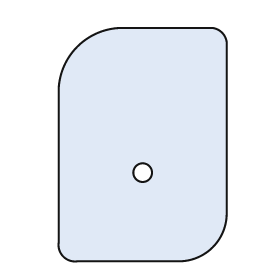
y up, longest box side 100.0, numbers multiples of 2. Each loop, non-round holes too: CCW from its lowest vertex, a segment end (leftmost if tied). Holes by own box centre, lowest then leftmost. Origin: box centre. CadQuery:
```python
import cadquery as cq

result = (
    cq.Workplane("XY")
    .moveTo(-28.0, -50.0)
    .lineTo(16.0, -50.0)
    .threePointArc((30.0, -44.0), (36.0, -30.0))
    .lineTo(36.0, 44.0)
    .threePointArc((34.0, 48.0), (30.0, 50.0))
    .lineTo(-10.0, 50.0)
    .threePointArc((-28.0, 42.0), (-36.0, 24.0))
    .lineTo(-36.0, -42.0)
    .threePointArc((-34.0, -48.0), (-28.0, -50.0))
    .close()
    .moveTo(0.0, -12.0)
    .circle(4.0)
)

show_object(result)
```